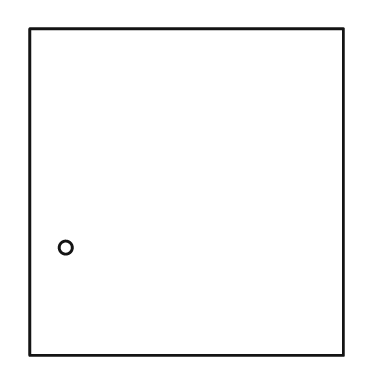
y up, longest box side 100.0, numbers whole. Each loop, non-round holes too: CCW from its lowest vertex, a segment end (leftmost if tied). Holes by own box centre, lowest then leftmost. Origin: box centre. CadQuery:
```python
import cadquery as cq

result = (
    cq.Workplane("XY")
    .moveTo(-48.0, -50.0)
    .lineTo(48.0, -50.0)
    .lineTo(48.0, 50.0)
    .lineTo(-48.0, 50.0)
    .close()
    .moveTo(-37.0, -17.0)
    .circle(2.0)
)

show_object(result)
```